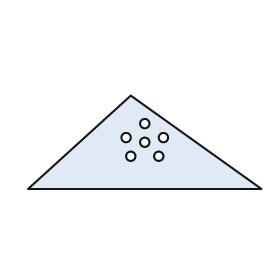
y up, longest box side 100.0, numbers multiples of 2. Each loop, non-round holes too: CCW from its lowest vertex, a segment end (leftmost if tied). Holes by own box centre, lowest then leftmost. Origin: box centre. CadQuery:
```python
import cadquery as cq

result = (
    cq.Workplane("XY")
    .moveTo(-50.0, -20.0)
    .lineTo(50.0, -20.0)
    .lineTo(-6.0, 20.0)
    .close()
    .moveTo(-6.0, -6.0)
    .circle(2.0)
    .moveTo(6.0, -6.0)
    .circle(2.0)
    .moveTo(0.0, 0.0)
    .circle(2.0)
    .moveTo(-8.0, 2.0)
    .circle(2.0)
    .moveTo(8.0, 2.0)
    .circle(2.0)
    .moveTo(0.0, 8.0)
    .circle(2.0)
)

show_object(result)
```